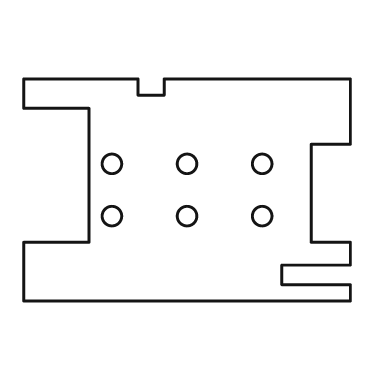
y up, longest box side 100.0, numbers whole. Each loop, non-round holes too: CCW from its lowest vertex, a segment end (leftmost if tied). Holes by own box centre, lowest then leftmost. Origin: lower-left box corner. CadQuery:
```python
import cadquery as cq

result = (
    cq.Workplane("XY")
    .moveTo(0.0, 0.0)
    .lineTo(100.0, 0.0)
    .lineTo(100.0, 5.0)
    .lineTo(79.0, 5.0)
    .lineTo(79.0, 11.0)
    .lineTo(100.0, 11.0)
    .lineTo(100.0, 18.0)
    .lineTo(88.0, 18.0)
    .lineTo(88.0, 48.0)
    .lineTo(100.0, 48.0)
    .lineTo(100.0, 68.0)
    .lineTo(43.0, 68.0)
    .lineTo(43.0, 63.0)
    .lineTo(35.0, 63.0)
    .lineTo(35.0, 68.0)
    .lineTo(0.0, 68.0)
    .lineTo(0.0, 59.0)
    .lineTo(20.0, 59.0)
    .lineTo(20.0, 18.0)
    .lineTo(0.0, 18.0)
    .close()
    .moveTo(27.0, 26.0)
    .circle(3.0)
    .moveTo(50.0, 26.0)
    .circle(3.0)
    .moveTo(73.0, 26.0)
    .circle(3.0)
    .moveTo(27.0, 42.0)
    .circle(3.0)
    .moveTo(50.0, 42.0)
    .circle(3.0)
    .moveTo(73.0, 42.0)
    .circle(3.0)
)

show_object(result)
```